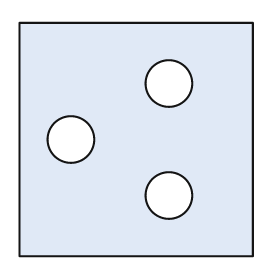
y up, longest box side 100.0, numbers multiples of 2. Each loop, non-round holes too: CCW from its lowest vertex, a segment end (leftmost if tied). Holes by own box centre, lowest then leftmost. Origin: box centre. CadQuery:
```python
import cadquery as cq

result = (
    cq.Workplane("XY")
    .moveTo(-50.0, -50.0)
    .lineTo(50.0, -50.0)
    .lineTo(50.0, 50.0)
    .lineTo(-50.0, 50.0)
    .close()
    .moveTo(14.0, -24.0)
    .circle(10.0)
    .moveTo(-28.0, 0.0)
    .circle(10.0)
    .moveTo(14.0, 24.0)
    .circle(10.0)
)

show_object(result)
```